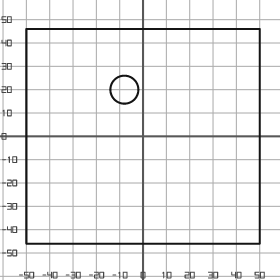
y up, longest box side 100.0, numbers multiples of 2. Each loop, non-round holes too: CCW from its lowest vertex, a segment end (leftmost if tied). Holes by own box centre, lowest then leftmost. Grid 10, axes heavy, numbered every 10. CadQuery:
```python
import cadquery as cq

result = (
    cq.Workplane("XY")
    .moveTo(-50.0, -46.0)
    .lineTo(50.0, -46.0)
    .lineTo(50.0, 46.0)
    .lineTo(-50.0, 46.0)
    .close()
    .moveTo(-8.0, 20.0)
    .circle(6.0)
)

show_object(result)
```